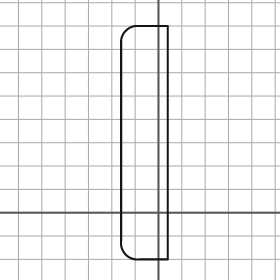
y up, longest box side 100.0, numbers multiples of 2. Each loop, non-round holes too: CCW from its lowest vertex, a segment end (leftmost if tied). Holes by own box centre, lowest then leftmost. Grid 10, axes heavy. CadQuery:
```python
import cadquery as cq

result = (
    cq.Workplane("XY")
    .moveTo(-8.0, -20.0)
    .lineTo(4.0, -20.0)
    .lineTo(4.0, 80.0)
    .lineTo(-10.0, 80.0)
    .threePointArc((-14.0, 78.0), (-16.0, 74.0))
    .lineTo(-16.0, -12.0)
    .threePointArc((-14.0, -18.0), (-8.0, -20.0))
    .close()
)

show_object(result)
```